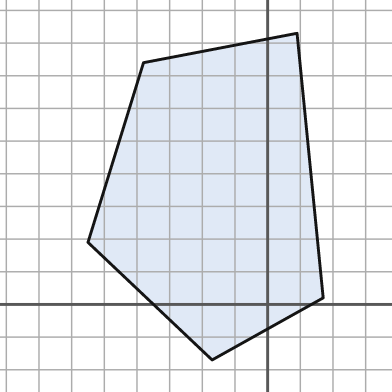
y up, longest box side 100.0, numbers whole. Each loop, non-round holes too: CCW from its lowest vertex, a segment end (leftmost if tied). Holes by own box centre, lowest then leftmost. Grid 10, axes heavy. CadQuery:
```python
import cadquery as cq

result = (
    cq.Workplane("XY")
    .moveTo(-17.0, -17.0)
    .lineTo(17.0, 2.0)
    .lineTo(9.0, 83.0)
    .lineTo(-38.0, 74.0)
    .lineTo(-55.0, 19.0)
    .close()
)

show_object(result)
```